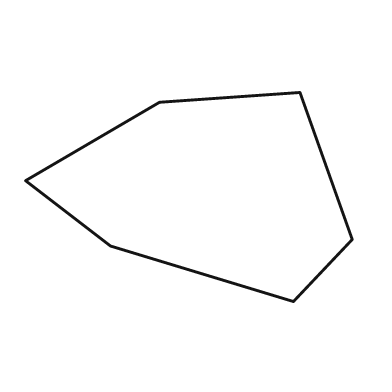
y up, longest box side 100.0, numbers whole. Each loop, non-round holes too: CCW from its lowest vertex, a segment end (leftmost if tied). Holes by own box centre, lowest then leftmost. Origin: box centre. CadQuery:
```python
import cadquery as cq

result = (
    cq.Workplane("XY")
    .moveTo(32.0, -32.0)
    .lineTo(50.0, -13.0)
    .lineTo(34.0, 32.0)
    .lineTo(-9.0, 29.0)
    .lineTo(-50.0, 5.0)
    .lineTo(-24.0, -15.0)
    .close()
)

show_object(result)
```